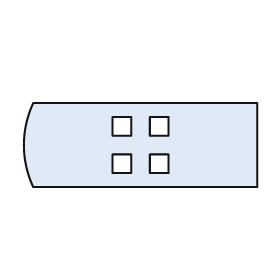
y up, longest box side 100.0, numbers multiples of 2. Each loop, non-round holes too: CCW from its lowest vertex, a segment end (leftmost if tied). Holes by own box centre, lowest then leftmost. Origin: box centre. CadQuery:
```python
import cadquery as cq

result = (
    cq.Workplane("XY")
    .moveTo(-46.0, -18.0)
    .lineTo(50.0, -18.0)
    .lineTo(50.0, 18.0)
    .lineTo(-46.0, 18.0)
    .threePointArc((-50.0, 0.0), (-46.0, -18.0))
    .close()
    .moveTo(-12.0, -12.0)
    .lineTo(-4.0, -12.0)
    .lineTo(-4.0, -4.0)
    .lineTo(-12.0, -4.0)
    .close()
    .moveTo(4.0, -12.0)
    .lineTo(12.0, -12.0)
    .lineTo(12.0, -4.0)
    .lineTo(4.0, -4.0)
    .close()
    .moveTo(-12.0, 4.0)
    .lineTo(-4.0, 4.0)
    .lineTo(-4.0, 12.0)
    .lineTo(-12.0, 12.0)
    .close()
    .moveTo(4.0, 4.0)
    .lineTo(12.0, 4.0)
    .lineTo(12.0, 12.0)
    .lineTo(4.0, 12.0)
    .close()
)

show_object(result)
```